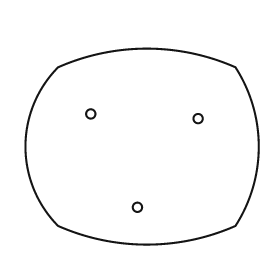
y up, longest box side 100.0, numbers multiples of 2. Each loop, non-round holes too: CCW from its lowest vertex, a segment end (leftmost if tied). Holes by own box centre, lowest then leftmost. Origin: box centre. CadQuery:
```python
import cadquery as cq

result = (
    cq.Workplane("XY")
    .moveTo(-36.0, -34.0)
    .threePointArc((2.0, -42.0), (40.0, -34.0))
    .threePointArc((50.0, 0.0), (40.0, 34.0))
    .threePointArc((2.0, 42.0), (-36.0, 34.0))
    .threePointArc((-50.0, 0.0), (-36.0, -34.0))
    .close()
    .moveTo(-2.0, -26.0)
    .circle(2.0)
    .moveTo(24.0, 12.0)
    .circle(2.0)
    .moveTo(-22.0, 14.0)
    .circle(2.0)
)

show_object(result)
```